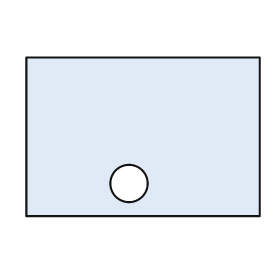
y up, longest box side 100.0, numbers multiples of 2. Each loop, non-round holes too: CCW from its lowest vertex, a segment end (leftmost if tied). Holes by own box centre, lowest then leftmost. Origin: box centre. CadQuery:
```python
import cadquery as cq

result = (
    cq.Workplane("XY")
    .moveTo(-50.0, -34.0)
    .lineTo(50.0, -34.0)
    .lineTo(50.0, 34.0)
    .lineTo(-50.0, 34.0)
    .close()
    .moveTo(-6.0, -20.0)
    .circle(8.0)
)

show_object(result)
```